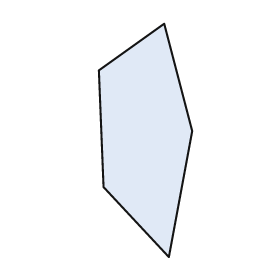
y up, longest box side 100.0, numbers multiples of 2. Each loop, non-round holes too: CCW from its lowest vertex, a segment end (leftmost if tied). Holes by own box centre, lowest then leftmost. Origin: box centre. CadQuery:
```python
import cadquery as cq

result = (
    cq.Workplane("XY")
    .moveTo(10.0, -50.0)
    .lineTo(20.0, 4.0)
    .lineTo(8.0, 50.0)
    .lineTo(-20.0, 30.0)
    .lineTo(-18.0, -20.0)
    .close()
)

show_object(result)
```